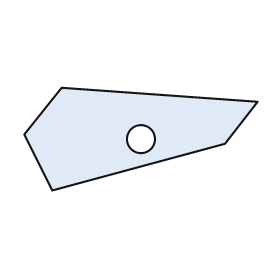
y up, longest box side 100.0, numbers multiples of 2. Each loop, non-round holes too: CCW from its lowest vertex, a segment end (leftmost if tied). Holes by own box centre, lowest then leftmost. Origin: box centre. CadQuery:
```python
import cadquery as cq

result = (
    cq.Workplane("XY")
    .moveTo(-38.0, -22.0)
    .lineTo(36.0, -2.0)
    .lineTo(50.0, 16.0)
    .lineTo(-34.0, 22.0)
    .lineTo(-50.0, 2.0)
    .close()
    .moveTo(0.0, 0.0)
    .circle(6.0)
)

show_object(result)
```